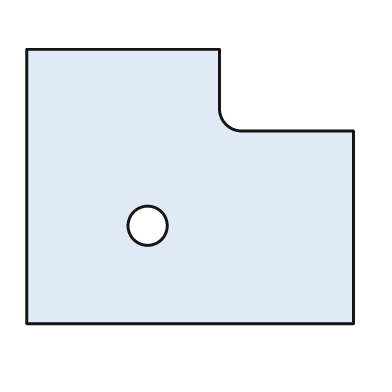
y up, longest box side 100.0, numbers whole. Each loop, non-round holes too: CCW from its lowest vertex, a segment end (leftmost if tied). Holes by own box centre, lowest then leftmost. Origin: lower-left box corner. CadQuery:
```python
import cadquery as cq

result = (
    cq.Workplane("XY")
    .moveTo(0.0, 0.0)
    .lineTo(100.0, 0.0)
    .lineTo(100.0, 59.0)
    .lineTo(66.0, 59.0)
    .threePointArc((61.0, 61.0), (59.0, 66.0))
    .lineTo(59.0, 84.0)
    .lineTo(0.0, 84.0)
    .close()
    .moveTo(37.0, 30.0)
    .circle(6.0)
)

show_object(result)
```